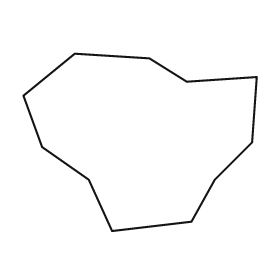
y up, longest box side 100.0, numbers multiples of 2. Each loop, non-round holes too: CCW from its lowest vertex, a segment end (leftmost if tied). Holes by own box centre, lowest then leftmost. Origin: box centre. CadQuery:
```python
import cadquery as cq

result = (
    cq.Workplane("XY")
    .moveTo(-12.0, -38.0)
    .lineTo(22.0, -34.0)
    .lineTo(32.0, -16.0)
    .lineTo(48.0, 0.0)
    .lineTo(50.0, 28.0)
    .lineTo(20.0, 26.0)
    .lineTo(4.0, 36.0)
    .lineTo(-28.0, 38.0)
    .lineTo(-50.0, 20.0)
    .lineTo(-42.0, -2.0)
    .lineTo(-22.0, -16.0)
    .close()
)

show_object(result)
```